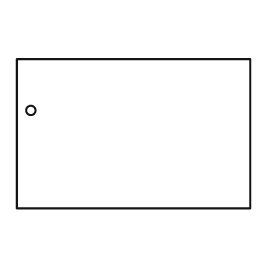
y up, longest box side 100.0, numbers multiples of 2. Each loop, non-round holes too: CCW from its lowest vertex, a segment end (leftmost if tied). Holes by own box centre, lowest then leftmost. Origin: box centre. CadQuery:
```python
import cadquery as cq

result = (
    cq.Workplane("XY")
    .moveTo(-50.0, -32.0)
    .lineTo(50.0, -32.0)
    .lineTo(50.0, 32.0)
    .lineTo(-50.0, 32.0)
    .close()
    .moveTo(-44.0, 10.0)
    .circle(2.0)
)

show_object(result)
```